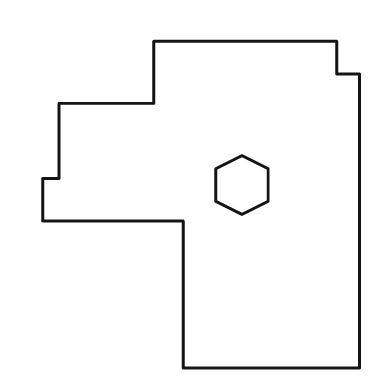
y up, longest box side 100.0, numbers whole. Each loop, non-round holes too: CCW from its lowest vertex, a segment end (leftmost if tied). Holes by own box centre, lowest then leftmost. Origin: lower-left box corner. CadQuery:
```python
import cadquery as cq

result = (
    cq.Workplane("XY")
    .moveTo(43.0, 0.0)
    .lineTo(97.0, 0.0)
    .lineTo(97.0, 90.0)
    .lineTo(90.0, 90.0)
    .lineTo(90.0, 100.0)
    .lineTo(34.0, 100.0)
    .lineTo(34.0, 81.0)
    .lineTo(5.0, 81.0)
    .lineTo(5.0, 58.0)
    .lineTo(0.0, 58.0)
    .lineTo(0.0, 45.0)
    .lineTo(43.0, 45.0)
    .close()
    .moveTo(61.0, 47.0)
    .lineTo(69.0, 51.0)
    .lineTo(69.0, 61.0)
    .lineTo(61.0, 65.0)
    .lineTo(53.0, 61.0)
    .lineTo(53.0, 51.0)
    .close()
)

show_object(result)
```